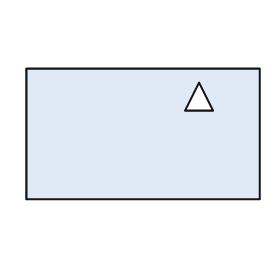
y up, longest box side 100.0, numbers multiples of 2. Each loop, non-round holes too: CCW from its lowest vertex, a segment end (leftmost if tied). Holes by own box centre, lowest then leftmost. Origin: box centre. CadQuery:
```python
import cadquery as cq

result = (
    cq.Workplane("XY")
    .moveTo(-50.0, -28.0)
    .lineTo(50.0, -28.0)
    .lineTo(50.0, 28.0)
    .lineTo(-50.0, 28.0)
    .close()
    .moveTo(18.0, 10.0)
    .lineTo(30.0, 10.0)
    .lineTo(24.0, 22.0)
    .close()
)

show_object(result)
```